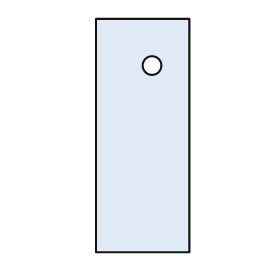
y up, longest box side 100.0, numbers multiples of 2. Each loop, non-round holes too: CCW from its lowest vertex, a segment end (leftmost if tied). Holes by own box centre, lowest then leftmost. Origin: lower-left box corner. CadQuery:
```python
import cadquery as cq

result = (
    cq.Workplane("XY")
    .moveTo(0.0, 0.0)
    .lineTo(40.0, 0.0)
    .lineTo(40.0, 100.0)
    .lineTo(0.0, 100.0)
    .close()
    .moveTo(24.0, 80.0)
    .circle(4.0)
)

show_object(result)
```